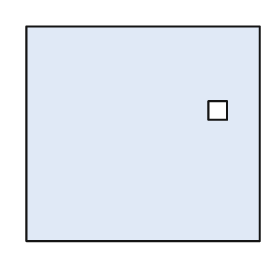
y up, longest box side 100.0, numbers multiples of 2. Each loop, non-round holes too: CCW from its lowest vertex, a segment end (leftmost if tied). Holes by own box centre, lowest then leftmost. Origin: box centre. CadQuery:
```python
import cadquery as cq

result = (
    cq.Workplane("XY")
    .moveTo(-50.0, -46.0)
    .lineTo(50.0, -46.0)
    .lineTo(50.0, 46.0)
    .lineTo(-50.0, 46.0)
    .close()
    .moveTo(28.0, 6.0)
    .lineTo(36.0, 6.0)
    .lineTo(36.0, 14.0)
    .lineTo(28.0, 14.0)
    .close()
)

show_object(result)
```